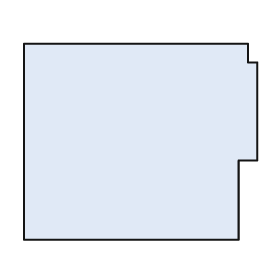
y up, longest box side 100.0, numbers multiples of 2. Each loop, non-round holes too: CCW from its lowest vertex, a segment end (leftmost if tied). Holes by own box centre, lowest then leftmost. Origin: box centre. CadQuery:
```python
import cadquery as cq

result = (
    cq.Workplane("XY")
    .moveTo(-50.0, -42.0)
    .lineTo(42.0, -42.0)
    .lineTo(42.0, -8.0)
    .lineTo(50.0, -8.0)
    .lineTo(50.0, 34.0)
    .lineTo(46.0, 34.0)
    .lineTo(46.0, 42.0)
    .lineTo(-50.0, 42.0)
    .close()
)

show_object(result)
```